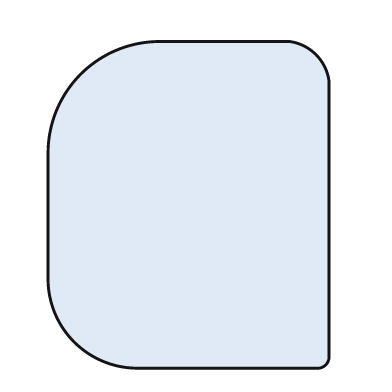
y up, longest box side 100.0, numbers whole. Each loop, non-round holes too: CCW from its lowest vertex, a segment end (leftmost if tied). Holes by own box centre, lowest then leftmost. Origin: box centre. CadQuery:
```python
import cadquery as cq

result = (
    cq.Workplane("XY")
    .moveTo(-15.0, -50.0)
    .lineTo(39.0, -50.0)
    .threePointArc((42.0, -49.0), (43.0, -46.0))
    .lineTo(43.0, 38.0)
    .threePointArc((39.0, 46.0), (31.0, 50.0))
    .lineTo(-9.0, 50.0)
    .threePointArc((-33.0, 40.0), (-43.0, 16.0))
    .lineTo(-43.0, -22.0)
    .threePointArc((-35.0, -42.0), (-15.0, -50.0))
    .close()
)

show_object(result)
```